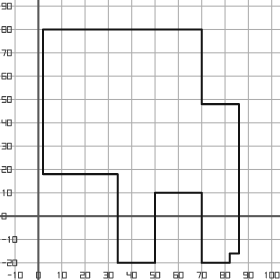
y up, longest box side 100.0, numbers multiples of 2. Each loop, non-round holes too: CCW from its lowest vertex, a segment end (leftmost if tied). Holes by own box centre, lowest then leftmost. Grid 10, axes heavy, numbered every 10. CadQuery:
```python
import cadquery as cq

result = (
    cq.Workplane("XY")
    .moveTo(34.0, -20.0)
    .lineTo(50.0, -20.0)
    .lineTo(50.0, 10.0)
    .lineTo(70.0, 10.0)
    .lineTo(70.0, -20.0)
    .lineTo(82.0, -20.0)
    .lineTo(82.0, -16.0)
    .lineTo(86.0, -16.0)
    .lineTo(86.0, 48.0)
    .lineTo(70.0, 48.0)
    .lineTo(70.0, 80.0)
    .lineTo(2.0, 80.0)
    .lineTo(2.0, 18.0)
    .lineTo(34.0, 18.0)
    .close()
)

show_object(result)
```